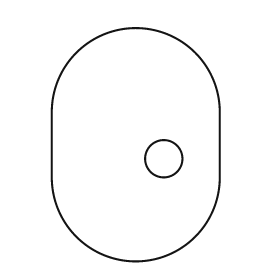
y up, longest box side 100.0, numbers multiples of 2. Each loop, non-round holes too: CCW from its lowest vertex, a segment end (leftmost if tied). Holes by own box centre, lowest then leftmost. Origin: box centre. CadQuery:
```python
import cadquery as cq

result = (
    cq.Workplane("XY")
    .moveTo(-36.0, -14.0)
    .threePointArc((0.0, -50.0), (36.0, -14.0))
    .lineTo(36.0, 14.0)
    .threePointArc((0.0, 50.0), (-36.0, 14.0))
    .close()
    .moveTo(12.0, -6.0)
    .circle(8.0)
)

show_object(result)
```